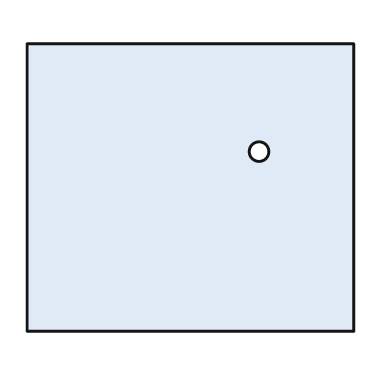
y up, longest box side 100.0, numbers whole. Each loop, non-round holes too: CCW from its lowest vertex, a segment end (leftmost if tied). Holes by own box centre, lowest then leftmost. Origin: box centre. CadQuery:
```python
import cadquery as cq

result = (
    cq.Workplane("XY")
    .moveTo(-50.0, -44.0)
    .lineTo(50.0, -44.0)
    .lineTo(50.0, 44.0)
    .lineTo(-50.0, 44.0)
    .close()
    .moveTo(21.0, 11.0)
    .circle(3.0)
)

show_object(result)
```